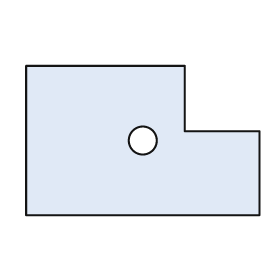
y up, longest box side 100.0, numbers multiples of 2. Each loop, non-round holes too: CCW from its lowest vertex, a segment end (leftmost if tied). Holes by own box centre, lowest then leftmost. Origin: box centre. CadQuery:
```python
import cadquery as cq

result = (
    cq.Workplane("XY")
    .moveTo(-50.0, -32.0)
    .lineTo(50.0, -32.0)
    .lineTo(50.0, 4.0)
    .lineTo(18.0, 4.0)
    .lineTo(18.0, 32.0)
    .lineTo(-50.0, 32.0)
    .close()
    .moveTo(0.0, 0.0)
    .circle(6.0)
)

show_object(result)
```